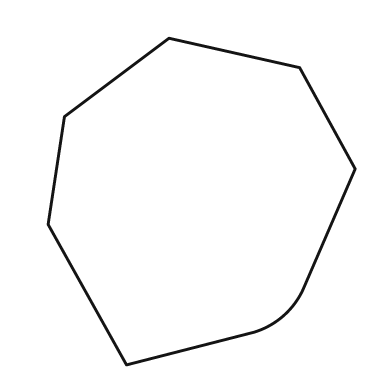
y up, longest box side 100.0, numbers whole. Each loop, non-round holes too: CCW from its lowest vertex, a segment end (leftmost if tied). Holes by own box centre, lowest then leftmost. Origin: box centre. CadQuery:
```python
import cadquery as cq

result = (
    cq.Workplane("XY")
    .moveTo(-23.0, -50.0)
    .lineTo(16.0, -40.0)
    .threePointArc((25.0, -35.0), (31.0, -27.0))
    .lineTo(47.0, 10.0)
    .lineTo(30.0, 41.0)
    .lineTo(-10.0, 50.0)
    .lineTo(-42.0, 26.0)
    .lineTo(-47.0, -7.0)
    .close()
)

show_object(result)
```